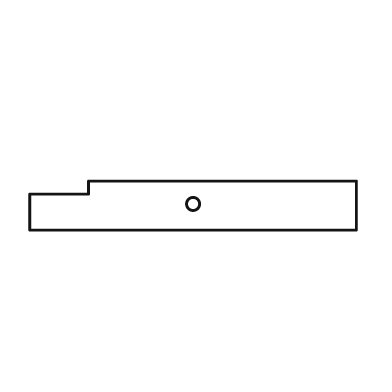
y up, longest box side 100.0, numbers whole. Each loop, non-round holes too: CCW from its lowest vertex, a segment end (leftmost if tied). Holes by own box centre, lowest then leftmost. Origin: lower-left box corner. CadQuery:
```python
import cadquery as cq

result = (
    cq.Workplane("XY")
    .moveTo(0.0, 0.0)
    .lineTo(100.0, 0.0)
    .lineTo(100.0, 15.0)
    .lineTo(18.0, 15.0)
    .lineTo(18.0, 11.0)
    .lineTo(0.0, 11.0)
    .close()
    .moveTo(50.0, 8.0)
    .circle(2.0)
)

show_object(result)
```